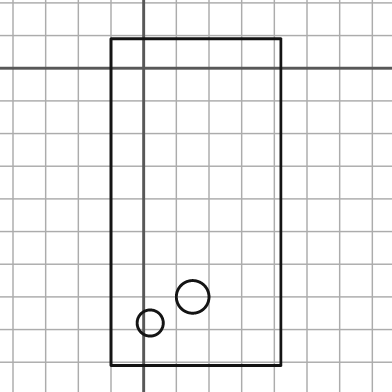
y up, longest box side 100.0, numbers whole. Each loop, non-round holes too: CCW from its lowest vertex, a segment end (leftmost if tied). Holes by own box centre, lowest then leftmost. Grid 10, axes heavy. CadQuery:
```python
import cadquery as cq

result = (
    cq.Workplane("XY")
    .moveTo(-10.0, -91.0)
    .lineTo(42.0, -91.0)
    .lineTo(42.0, 9.0)
    .lineTo(-10.0, 9.0)
    .close()
    .moveTo(2.0, -78.0)
    .circle(4.0)
    .moveTo(15.0, -70.0)
    .circle(5.0)
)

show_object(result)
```